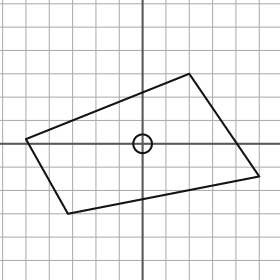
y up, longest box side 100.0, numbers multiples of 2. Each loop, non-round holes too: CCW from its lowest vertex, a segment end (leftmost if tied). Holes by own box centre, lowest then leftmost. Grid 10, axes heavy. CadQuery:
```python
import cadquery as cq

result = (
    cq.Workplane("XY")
    .moveTo(-32.0, -30.0)
    .lineTo(50.0, -14.0)
    .lineTo(20.0, 30.0)
    .lineTo(-50.0, 2.0)
    .close()
    .moveTo(0.0, 0.0)
    .circle(4.0)
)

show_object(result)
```